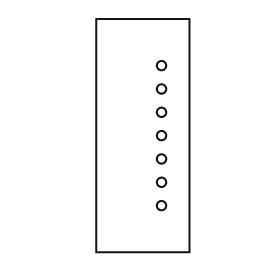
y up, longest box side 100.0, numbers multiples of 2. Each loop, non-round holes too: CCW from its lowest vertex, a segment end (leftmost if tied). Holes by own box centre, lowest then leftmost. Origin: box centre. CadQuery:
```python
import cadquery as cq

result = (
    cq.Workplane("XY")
    .moveTo(-20.0, -50.0)
    .lineTo(20.0, -50.0)
    .lineTo(20.0, 50.0)
    .lineTo(-20.0, 50.0)
    .close()
    .moveTo(8.0, -30.0)
    .circle(2.0)
    .moveTo(8.0, -20.0)
    .circle(2.0)
    .moveTo(8.0, -10.0)
    .circle(2.0)
    .moveTo(8.0, 0.0)
    .circle(2.0)
    .moveTo(8.0, 10.0)
    .circle(2.0)
    .moveTo(8.0, 20.0)
    .circle(2.0)
    .moveTo(8.0, 30.0)
    .circle(2.0)
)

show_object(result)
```